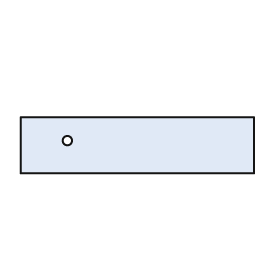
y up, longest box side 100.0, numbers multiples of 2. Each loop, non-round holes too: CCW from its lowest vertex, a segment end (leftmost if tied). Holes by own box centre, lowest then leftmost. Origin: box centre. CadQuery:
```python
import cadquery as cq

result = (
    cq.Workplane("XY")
    .moveTo(-50.0, -12.0)
    .lineTo(50.0, -12.0)
    .lineTo(50.0, 12.0)
    .lineTo(-50.0, 12.0)
    .close()
    .moveTo(-30.0, 2.0)
    .circle(2.0)
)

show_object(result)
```